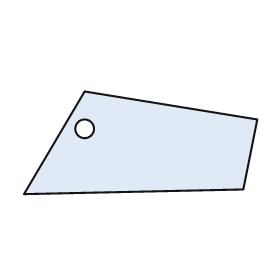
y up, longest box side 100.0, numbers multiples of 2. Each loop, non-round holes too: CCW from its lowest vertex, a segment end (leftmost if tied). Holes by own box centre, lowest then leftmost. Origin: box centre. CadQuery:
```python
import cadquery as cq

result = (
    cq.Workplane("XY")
    .moveTo(-50.0, -22.0)
    .lineTo(44.0, -20.0)
    .lineTo(50.0, 10.0)
    .lineTo(-24.0, 22.0)
    .close()
    .moveTo(-24.0, 6.0)
    .circle(4.0)
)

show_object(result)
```